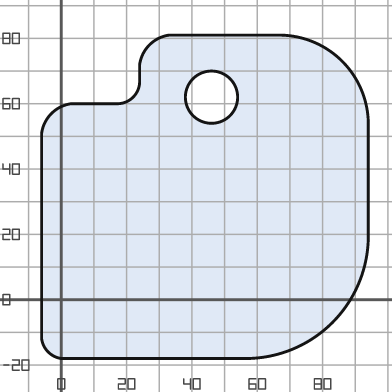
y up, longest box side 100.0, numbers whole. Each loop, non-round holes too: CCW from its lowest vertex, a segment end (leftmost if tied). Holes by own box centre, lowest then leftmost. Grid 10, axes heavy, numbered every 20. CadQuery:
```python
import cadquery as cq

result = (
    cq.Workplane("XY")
    .moveTo(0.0, -18.0)
    .lineTo(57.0, -18.0)
    .threePointArc((83.0, -7.0), (94.0, 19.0))
    .lineTo(94.0, 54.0)
    .threePointArc((86.0, 73.0), (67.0, 81.0))
    .lineTo(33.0, 81.0)
    .threePointArc((27.0, 78.0), (24.0, 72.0))
    .lineTo(24.0, 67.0)
    .threePointArc((22.0, 62.0), (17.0, 60.0))
    .lineTo(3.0, 60.0)
    .threePointArc((-3.0, 57.0), (-6.0, 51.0))
    .lineTo(-6.0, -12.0)
    .threePointArc((-4.0, -16.0), (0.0, -18.0))
    .close()
    .moveTo(46.0, 62.0)
    .circle(8.0)
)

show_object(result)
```